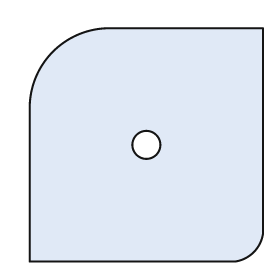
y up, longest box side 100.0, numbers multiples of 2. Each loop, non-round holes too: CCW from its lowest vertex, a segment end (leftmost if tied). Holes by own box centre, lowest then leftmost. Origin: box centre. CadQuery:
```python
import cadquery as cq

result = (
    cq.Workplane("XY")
    .moveTo(-50.0, -50.0)
    .lineTo(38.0, -50.0)
    .threePointArc((46.0, -46.0), (50.0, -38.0))
    .lineTo(50.0, 50.0)
    .lineTo(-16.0, 50.0)
    .threePointArc((-40.0, 40.0), (-50.0, 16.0))
    .close()
    .moveTo(0.0, 0.0)
    .circle(6.0)
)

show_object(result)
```